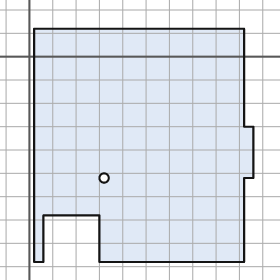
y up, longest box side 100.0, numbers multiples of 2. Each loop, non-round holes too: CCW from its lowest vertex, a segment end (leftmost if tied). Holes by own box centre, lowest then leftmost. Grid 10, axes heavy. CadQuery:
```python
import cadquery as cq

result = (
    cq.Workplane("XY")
    .moveTo(2.0, -88.0)
    .lineTo(6.0, -88.0)
    .lineTo(6.0, -68.0)
    .lineTo(30.0, -68.0)
    .lineTo(30.0, -88.0)
    .lineTo(92.0, -88.0)
    .lineTo(92.0, -52.0)
    .lineTo(96.0, -52.0)
    .lineTo(96.0, -30.0)
    .lineTo(92.0, -30.0)
    .lineTo(92.0, 12.0)
    .lineTo(2.0, 12.0)
    .close()
    .moveTo(32.0, -52.0)
    .circle(2.0)
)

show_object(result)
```